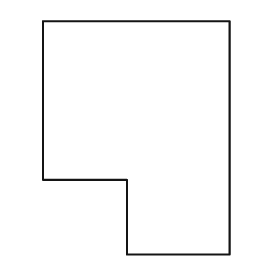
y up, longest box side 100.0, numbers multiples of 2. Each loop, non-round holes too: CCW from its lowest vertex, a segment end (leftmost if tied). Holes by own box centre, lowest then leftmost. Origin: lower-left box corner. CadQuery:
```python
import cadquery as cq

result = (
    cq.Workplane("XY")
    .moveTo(36.0, 0.0)
    .lineTo(80.0, 0.0)
    .lineTo(80.0, 100.0)
    .lineTo(0.0, 100.0)
    .lineTo(0.0, 32.0)
    .lineTo(36.0, 32.0)
    .close()
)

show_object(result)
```